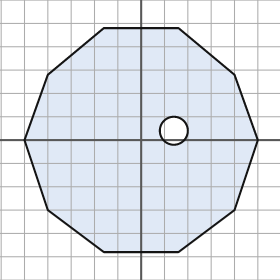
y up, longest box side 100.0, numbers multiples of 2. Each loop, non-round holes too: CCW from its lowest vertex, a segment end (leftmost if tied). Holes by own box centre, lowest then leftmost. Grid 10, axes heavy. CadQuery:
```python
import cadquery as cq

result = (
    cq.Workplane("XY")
    .moveTo(-16.0, -48.0)
    .lineTo(16.0, -48.0)
    .lineTo(40.0, -30.0)
    .lineTo(50.0, 0.0)
    .lineTo(40.0, 28.0)
    .lineTo(16.0, 48.0)
    .lineTo(-16.0, 48.0)
    .lineTo(-40.0, 28.0)
    .lineTo(-50.0, 0.0)
    .lineTo(-40.0, -30.0)
    .close()
    .moveTo(14.0, 4.0)
    .circle(6.0)
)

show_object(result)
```